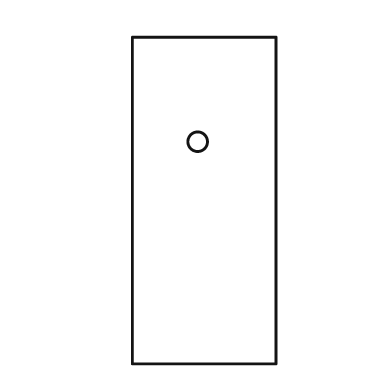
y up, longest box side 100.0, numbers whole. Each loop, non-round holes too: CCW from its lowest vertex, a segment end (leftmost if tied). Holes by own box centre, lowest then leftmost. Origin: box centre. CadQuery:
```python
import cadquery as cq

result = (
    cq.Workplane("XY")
    .moveTo(-22.0, -50.0)
    .lineTo(22.0, -50.0)
    .lineTo(22.0, 50.0)
    .lineTo(-22.0, 50.0)
    .close()
    .moveTo(-2.0, 18.0)
    .circle(3.0)
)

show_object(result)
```